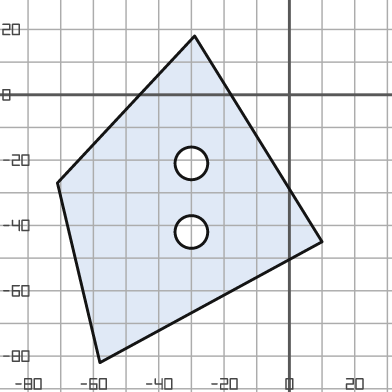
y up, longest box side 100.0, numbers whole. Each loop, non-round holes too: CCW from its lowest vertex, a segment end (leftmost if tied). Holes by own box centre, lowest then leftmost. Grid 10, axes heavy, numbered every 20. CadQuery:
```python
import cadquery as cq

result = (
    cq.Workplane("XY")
    .moveTo(-58.0, -82.0)
    .lineTo(10.0, -45.0)
    .lineTo(-29.0, 18.0)
    .lineTo(-71.0, -27.0)
    .close()
    .moveTo(-30.0, -42.0)
    .circle(5.0)
    .moveTo(-30.0, -21.0)
    .circle(5.0)
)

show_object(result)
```